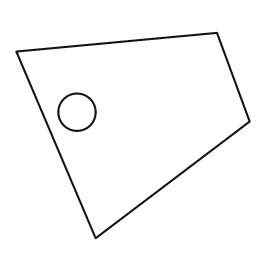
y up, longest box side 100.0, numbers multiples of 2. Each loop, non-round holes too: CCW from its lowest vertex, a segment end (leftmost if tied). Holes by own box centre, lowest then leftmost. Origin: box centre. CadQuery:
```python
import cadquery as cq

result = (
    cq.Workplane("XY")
    .moveTo(-16.0, -44.0)
    .lineTo(50.0, 6.0)
    .lineTo(36.0, 44.0)
    .lineTo(-50.0, 36.0)
    .close()
    .moveTo(-24.0, 10.0)
    .circle(8.0)
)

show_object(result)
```